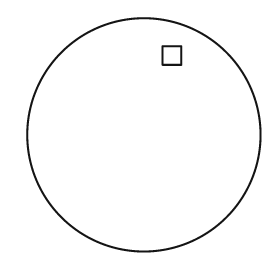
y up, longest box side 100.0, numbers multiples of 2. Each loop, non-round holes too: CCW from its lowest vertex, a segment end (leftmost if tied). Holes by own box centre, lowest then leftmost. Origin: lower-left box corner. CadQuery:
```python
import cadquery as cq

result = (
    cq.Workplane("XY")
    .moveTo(50.0, 50.0)
    .circle(50.0)
    .moveTo(58.0, 80.0)
    .lineTo(66.0, 80.0)
    .lineTo(66.0, 88.0)
    .lineTo(58.0, 88.0)
    .close()
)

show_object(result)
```